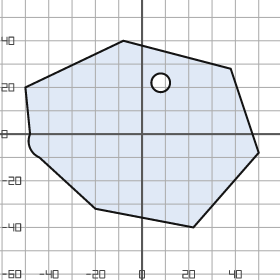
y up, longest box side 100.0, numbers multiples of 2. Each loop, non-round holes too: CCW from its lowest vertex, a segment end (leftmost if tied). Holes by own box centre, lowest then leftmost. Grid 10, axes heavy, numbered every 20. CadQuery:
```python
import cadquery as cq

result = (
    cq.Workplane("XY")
    .moveTo(22.0, -40.0)
    .lineTo(50.0, -8.0)
    .lineTo(38.0, 28.0)
    .lineTo(-8.0, 40.0)
    .lineTo(-50.0, 20.0)
    .lineTo(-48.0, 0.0)
    .threePointArc((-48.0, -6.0), (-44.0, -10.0))
    .lineTo(-20.0, -32.0)
    .close()
    .moveTo(8.0, 22.0)
    .circle(4.0)
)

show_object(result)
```